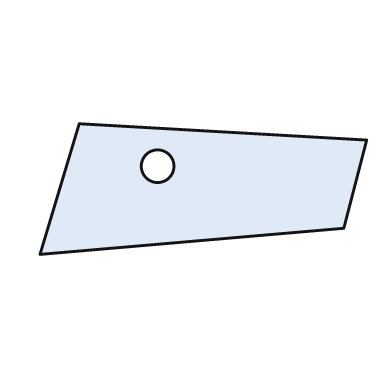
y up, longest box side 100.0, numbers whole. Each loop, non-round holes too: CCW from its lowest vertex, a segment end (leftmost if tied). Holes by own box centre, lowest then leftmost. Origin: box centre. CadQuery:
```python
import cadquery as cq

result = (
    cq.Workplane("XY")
    .moveTo(-50.0, -20.0)
    .lineTo(43.0, -12.0)
    .lineTo(50.0, 15.0)
    .lineTo(-38.0, 20.0)
    .close()
    .moveTo(-14.0, 7.0)
    .circle(5.0)
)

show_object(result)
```